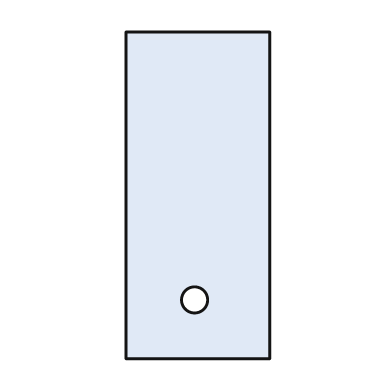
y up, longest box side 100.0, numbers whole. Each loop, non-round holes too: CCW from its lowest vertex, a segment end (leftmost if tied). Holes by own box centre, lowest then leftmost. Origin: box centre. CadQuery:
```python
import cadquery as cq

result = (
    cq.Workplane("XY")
    .moveTo(-22.0, -50.0)
    .lineTo(22.0, -50.0)
    .lineTo(22.0, 50.0)
    .lineTo(-22.0, 50.0)
    .close()
    .moveTo(-1.0, -32.0)
    .circle(4.0)
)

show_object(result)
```